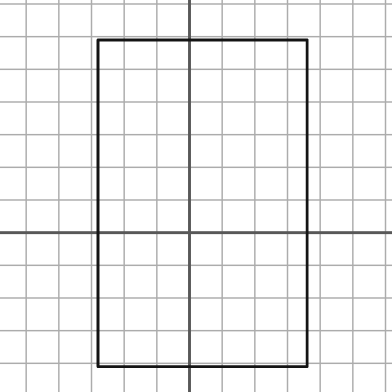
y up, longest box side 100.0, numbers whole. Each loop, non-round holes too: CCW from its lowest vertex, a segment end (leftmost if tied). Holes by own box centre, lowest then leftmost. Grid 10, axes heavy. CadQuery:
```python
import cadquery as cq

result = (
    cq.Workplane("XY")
    .moveTo(-28.0, -41.0)
    .lineTo(36.0, -41.0)
    .lineTo(36.0, 59.0)
    .lineTo(-28.0, 59.0)
    .close()
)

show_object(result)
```